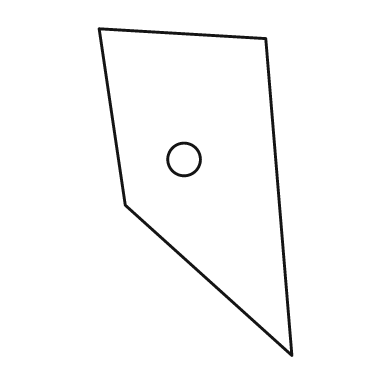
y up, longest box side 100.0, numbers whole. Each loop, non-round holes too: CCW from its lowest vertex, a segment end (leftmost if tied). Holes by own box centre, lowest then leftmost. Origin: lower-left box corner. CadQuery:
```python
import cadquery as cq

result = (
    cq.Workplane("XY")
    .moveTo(59.0, 0.0)
    .lineTo(51.0, 97.0)
    .lineTo(0.0, 100.0)
    .lineTo(8.0, 46.0)
    .close()
    .moveTo(26.0, 60.0)
    .circle(5.0)
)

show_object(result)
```